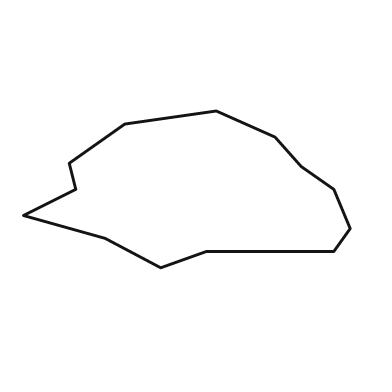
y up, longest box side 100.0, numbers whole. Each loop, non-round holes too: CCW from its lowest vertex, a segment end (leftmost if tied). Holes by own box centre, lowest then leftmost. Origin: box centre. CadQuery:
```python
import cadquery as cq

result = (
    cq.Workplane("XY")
    .moveTo(-8.0, -24.0)
    .lineTo(6.0, -19.0)
    .lineTo(45.0, -19.0)
    .lineTo(50.0, -12.0)
    .lineTo(45.0, 0.0)
    .lineTo(35.0, 7.0)
    .lineTo(27.0, 16.0)
    .lineTo(9.0, 24.0)
    .lineTo(-19.0, 20.0)
    .lineTo(-36.0, 8.0)
    .lineTo(-34.0, 0.0)
    .lineTo(-50.0, -8.0)
    .lineTo(-25.0, -15.0)
    .close()
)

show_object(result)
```